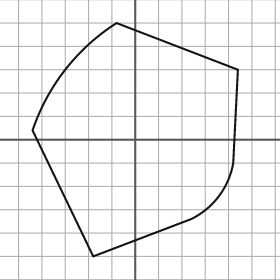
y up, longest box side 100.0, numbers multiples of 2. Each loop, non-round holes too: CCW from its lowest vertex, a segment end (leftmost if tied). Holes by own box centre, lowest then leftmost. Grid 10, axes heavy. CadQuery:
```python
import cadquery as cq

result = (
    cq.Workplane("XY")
    .moveTo(-18.0, -50.0)
    .lineTo(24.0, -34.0)
    .threePointArc((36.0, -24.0), (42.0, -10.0))
    .lineTo(44.0, 30.0)
    .lineTo(-8.0, 50.0)
    .threePointArc((-30.0, 30.0), (-44.0, 4.0))
    .close()
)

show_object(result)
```